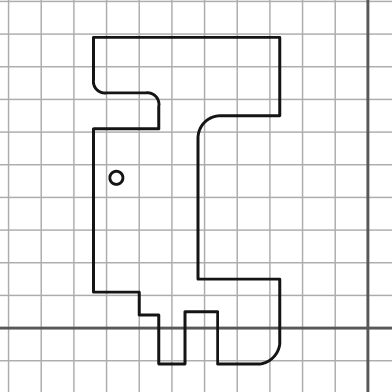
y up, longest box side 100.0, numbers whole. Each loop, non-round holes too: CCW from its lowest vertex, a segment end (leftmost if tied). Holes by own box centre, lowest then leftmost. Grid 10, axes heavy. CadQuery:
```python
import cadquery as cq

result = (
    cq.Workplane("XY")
    .moveTo(-64.0, -11.0)
    .lineTo(-56.0, -11.0)
    .lineTo(-56.0, 5.0)
    .lineTo(-46.0, 5.0)
    .lineTo(-46.0, -11.0)
    .lineTo(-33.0, -11.0)
    .threePointArc((-29.0, -9.0), (-27.0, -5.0))
    .lineTo(-27.0, 15.0)
    .lineTo(-52.0, 15.0)
    .lineTo(-52.0, 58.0)
    .threePointArc((-50.0, 63.0), (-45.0, 65.0))
    .lineTo(-27.0, 65.0)
    .lineTo(-27.0, 89.0)
    .lineTo(-84.0, 89.0)
    .lineTo(-84.0, 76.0)
    .threePointArc((-83.0, 73.0), (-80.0, 72.0))
    .lineTo(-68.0, 72.0)
    .threePointArc((-65.0, 71.0), (-64.0, 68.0))
    .lineTo(-64.0, 61.0)
    .lineTo(-84.0, 61.0)
    .lineTo(-84.0, 11.0)
    .lineTo(-70.0, 11.0)
    .lineTo(-70.0, 4.0)
    .lineTo(-64.0, 4.0)
    .close()
    .moveTo(-77.0, 46.0)
    .circle(2.0)
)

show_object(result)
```